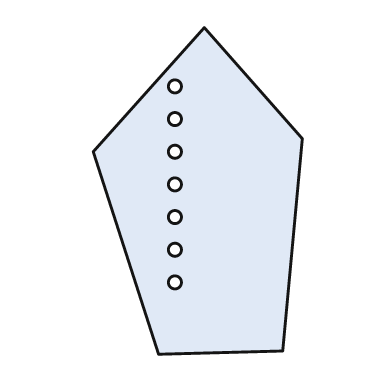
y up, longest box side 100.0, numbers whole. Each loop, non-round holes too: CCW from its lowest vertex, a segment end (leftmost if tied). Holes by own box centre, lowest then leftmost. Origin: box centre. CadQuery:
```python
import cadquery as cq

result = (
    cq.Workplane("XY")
    .moveTo(-12.0, -50.0)
    .lineTo(26.0, -49.0)
    .lineTo(32.0, 16.0)
    .lineTo(2.0, 50.0)
    .lineTo(-32.0, 12.0)
    .close()
    .moveTo(-7.0, -28.0)
    .circle(2.0)
    .moveTo(-7.0, -18.0)
    .circle(2.0)
    .moveTo(-7.0, -8.0)
    .circle(2.0)
    .moveTo(-7.0, 2.0)
    .circle(2.0)
    .moveTo(-7.0, 12.0)
    .circle(2.0)
    .moveTo(-7.0, 22.0)
    .circle(2.0)
    .moveTo(-7.0, 32.0)
    .circle(2.0)
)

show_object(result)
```